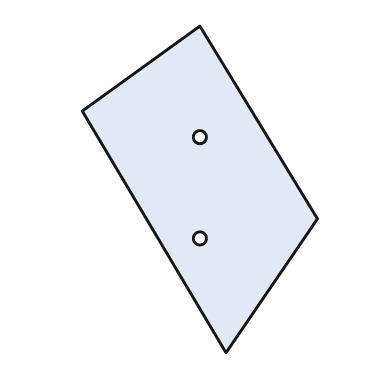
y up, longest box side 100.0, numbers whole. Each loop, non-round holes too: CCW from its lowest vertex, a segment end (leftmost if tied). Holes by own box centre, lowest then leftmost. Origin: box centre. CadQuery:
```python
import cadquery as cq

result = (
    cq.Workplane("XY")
    .moveTo(8.0, -50.0)
    .lineTo(36.0, -9.0)
    .lineTo(0.0, 50.0)
    .lineTo(-36.0, 24.0)
    .close()
    .moveTo(0.0, -15.0)
    .circle(2.0)
    .moveTo(0.0, 16.0)
    .circle(2.0)
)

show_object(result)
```